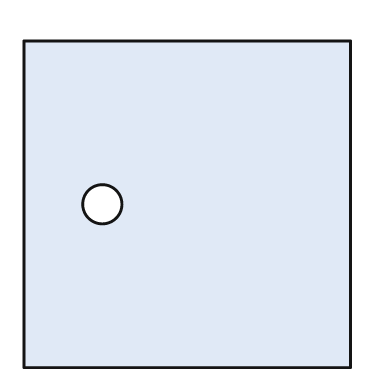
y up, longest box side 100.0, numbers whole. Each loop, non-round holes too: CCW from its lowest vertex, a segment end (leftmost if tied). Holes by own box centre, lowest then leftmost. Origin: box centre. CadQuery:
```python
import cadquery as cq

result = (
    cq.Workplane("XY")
    .moveTo(-50.0, -50.0)
    .lineTo(50.0, -50.0)
    .lineTo(50.0, 50.0)
    .lineTo(-50.0, 50.0)
    .close()
    .moveTo(-26.0, 0.0)
    .circle(6.0)
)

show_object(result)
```